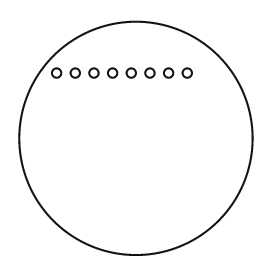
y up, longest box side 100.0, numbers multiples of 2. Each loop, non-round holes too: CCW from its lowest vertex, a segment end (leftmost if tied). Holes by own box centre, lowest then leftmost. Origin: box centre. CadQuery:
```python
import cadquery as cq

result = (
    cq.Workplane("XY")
    .moveTo(0.0, 0.0)
    .circle(50.0)
    .moveTo(-34.0, 28.0)
    .circle(2.0)
    .moveTo(-26.0, 28.0)
    .circle(2.0)
    .moveTo(-18.0, 28.0)
    .circle(2.0)
    .moveTo(-10.0, 28.0)
    .circle(2.0)
    .moveTo(-2.0, 28.0)
    .circle(2.0)
    .moveTo(6.0, 28.0)
    .circle(2.0)
    .moveTo(14.0, 28.0)
    .circle(2.0)
    .moveTo(22.0, 28.0)
    .circle(2.0)
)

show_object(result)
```